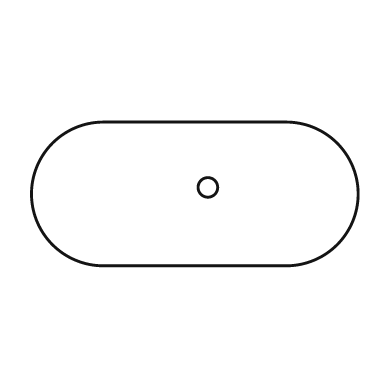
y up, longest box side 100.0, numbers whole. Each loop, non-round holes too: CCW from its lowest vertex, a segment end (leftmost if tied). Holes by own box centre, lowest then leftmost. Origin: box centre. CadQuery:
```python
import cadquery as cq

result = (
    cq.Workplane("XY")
    .moveTo(-28.0, -22.0)
    .lineTo(28.0, -22.0)
    .threePointArc((50.0, 0.0), (28.0, 22.0))
    .lineTo(-28.0, 22.0)
    .threePointArc((-50.0, 0.0), (-28.0, -22.0))
    .close()
    .moveTo(4.0, 2.0)
    .circle(3.0)
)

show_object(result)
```